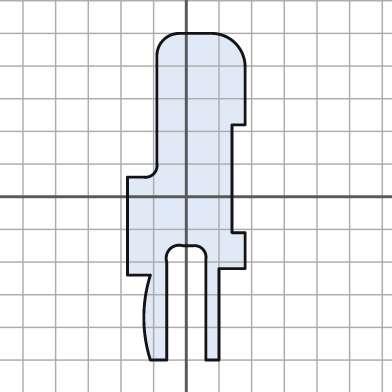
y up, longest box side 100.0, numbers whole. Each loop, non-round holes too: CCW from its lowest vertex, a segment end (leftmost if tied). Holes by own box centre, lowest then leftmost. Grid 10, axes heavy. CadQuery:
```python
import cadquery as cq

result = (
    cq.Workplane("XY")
    .moveTo(-11.0, -50.0)
    .lineTo(-6.0, -50.0)
    .lineTo(-6.0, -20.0)
    .threePointArc((-5.0, -16.0), (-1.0, -15.0))
    .lineTo(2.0, -15.0)
    .threePointArc((5.0, -16.0), (6.0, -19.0))
    .lineTo(6.0, -50.0)
    .lineTo(10.0, -50.0)
    .lineTo(10.0, -22.0)
    .lineTo(18.0, -22.0)
    .lineTo(18.0, -11.0)
    .lineTo(14.0, -11.0)
    .lineTo(14.0, 22.0)
    .lineTo(18.0, 22.0)
    .lineTo(18.0, 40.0)
    .threePointArc((15.0, 47.0), (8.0, 50.0))
    .lineTo(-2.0, 50.0)
    .threePointArc((-7.0, 48.0), (-9.0, 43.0))
    .lineTo(-9.0, 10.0)
    .threePointArc((-10.0, 7.0), (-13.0, 6.0))
    .lineTo(-18.0, 6.0)
    .lineTo(-18.0, -24.0)
    .lineTo(-11.0, -24.0)
    .threePointArc((-13.0, -37.0), (-11.0, -50.0))
    .close()
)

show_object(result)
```